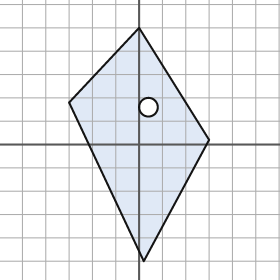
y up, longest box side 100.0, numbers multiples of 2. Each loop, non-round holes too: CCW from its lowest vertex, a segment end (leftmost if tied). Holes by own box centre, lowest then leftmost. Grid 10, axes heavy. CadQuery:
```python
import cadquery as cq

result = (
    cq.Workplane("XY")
    .moveTo(2.0, -50.0)
    .lineTo(30.0, 2.0)
    .lineTo(0.0, 50.0)
    .lineTo(-30.0, 18.0)
    .close()
    .moveTo(4.0, 16.0)
    .circle(4.0)
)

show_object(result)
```